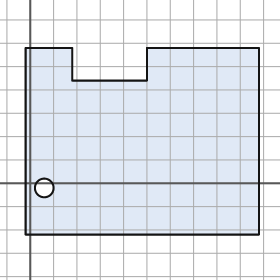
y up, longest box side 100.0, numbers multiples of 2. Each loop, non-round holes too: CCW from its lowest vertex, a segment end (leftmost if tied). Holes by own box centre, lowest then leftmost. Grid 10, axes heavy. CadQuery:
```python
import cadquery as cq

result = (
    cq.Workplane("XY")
    .moveTo(-2.0, -22.0)
    .lineTo(98.0, -22.0)
    .lineTo(98.0, 58.0)
    .lineTo(50.0, 58.0)
    .lineTo(50.0, 44.0)
    .lineTo(18.0, 44.0)
    .lineTo(18.0, 58.0)
    .lineTo(-2.0, 58.0)
    .close()
    .moveTo(6.0, -2.0)
    .circle(4.0)
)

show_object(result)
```